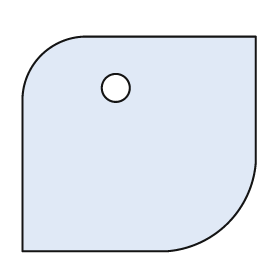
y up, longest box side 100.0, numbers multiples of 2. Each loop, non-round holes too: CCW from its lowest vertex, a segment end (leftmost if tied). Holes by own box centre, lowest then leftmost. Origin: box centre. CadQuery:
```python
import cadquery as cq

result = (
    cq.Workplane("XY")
    .moveTo(-50.0, -46.0)
    .lineTo(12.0, -46.0)
    .threePointArc((38.0, -34.0), (50.0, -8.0))
    .lineTo(50.0, 46.0)
    .lineTo(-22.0, 46.0)
    .threePointArc((-42.0, 38.0), (-50.0, 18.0))
    .close()
    .moveTo(-10.0, 24.0)
    .circle(6.0)
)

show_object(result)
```